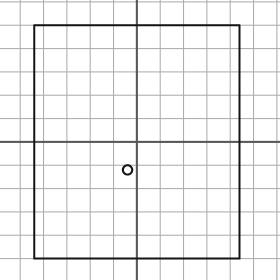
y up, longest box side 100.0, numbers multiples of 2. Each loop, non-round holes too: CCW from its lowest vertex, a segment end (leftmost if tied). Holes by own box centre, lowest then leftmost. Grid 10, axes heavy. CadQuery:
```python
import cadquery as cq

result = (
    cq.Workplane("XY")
    .moveTo(-44.0, -50.0)
    .lineTo(44.0, -50.0)
    .lineTo(44.0, 50.0)
    .lineTo(-44.0, 50.0)
    .close()
    .moveTo(-4.0, -12.0)
    .circle(2.0)
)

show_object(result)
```